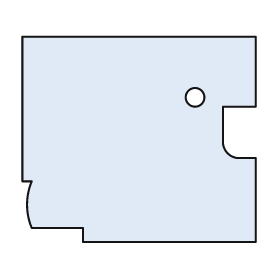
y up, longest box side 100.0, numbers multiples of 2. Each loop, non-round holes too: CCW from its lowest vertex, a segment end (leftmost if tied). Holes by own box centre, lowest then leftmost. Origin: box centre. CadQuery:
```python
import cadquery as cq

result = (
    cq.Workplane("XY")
    .moveTo(-24.0, -44.0)
    .lineTo(50.0, -44.0)
    .lineTo(50.0, -8.0)
    .lineTo(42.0, -8.0)
    .threePointArc((38.0, -6.0), (36.0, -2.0))
    .lineTo(36.0, 14.0)
    .lineTo(50.0, 14.0)
    .lineTo(50.0, 44.0)
    .lineTo(-50.0, 44.0)
    .lineTo(-50.0, -18.0)
    .lineTo(-46.0, -18.0)
    .threePointArc((-48.0, -28.0), (-46.0, -38.0))
    .lineTo(-24.0, -38.0)
    .close()
    .moveTo(24.0, 18.0)
    .circle(4.0)
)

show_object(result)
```